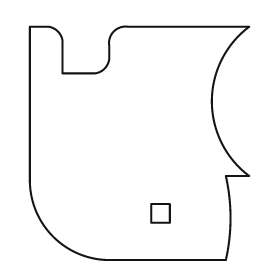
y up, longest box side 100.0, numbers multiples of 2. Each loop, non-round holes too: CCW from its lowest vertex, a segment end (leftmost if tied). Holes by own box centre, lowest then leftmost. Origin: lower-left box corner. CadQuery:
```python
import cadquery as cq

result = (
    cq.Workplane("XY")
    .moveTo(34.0, 0.0)
    .lineTo(84.0, 0.0)
    .threePointArc((86.0, 18.0), (84.0, 36.0))
    .lineTo(94.0, 36.0)
    .threePointArc((78.0, 68.0), (94.0, 100.0))
    .lineTo(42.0, 100.0)
    .threePointArc((36.0, 98.0), (34.0, 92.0))
    .lineTo(34.0, 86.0)
    .threePointArc((32.0, 82.0), (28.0, 80.0))
    .lineTo(14.0, 80.0)
    .lineTo(14.0, 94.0)
    .threePointArc((12.0, 98.0), (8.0, 100.0))
    .lineTo(0.0, 100.0)
    .lineTo(0.0, 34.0)
    .threePointArc((10.0, 10.0), (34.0, 0.0))
    .close()
    .moveTo(52.0, 16.0)
    .lineTo(60.0, 16.0)
    .lineTo(60.0, 24.0)
    .lineTo(52.0, 24.0)
    .close()
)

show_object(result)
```